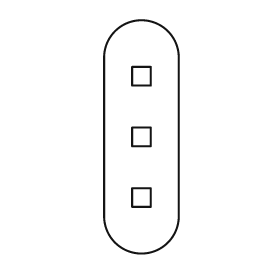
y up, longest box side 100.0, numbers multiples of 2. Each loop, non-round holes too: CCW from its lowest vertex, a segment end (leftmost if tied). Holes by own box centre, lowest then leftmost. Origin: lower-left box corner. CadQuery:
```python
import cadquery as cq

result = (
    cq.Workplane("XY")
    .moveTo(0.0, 16.0)
    .threePointArc((16.0, 0.0), (32.0, 16.0))
    .lineTo(32.0, 84.0)
    .threePointArc((16.0, 100.0), (0.0, 84.0))
    .close()
    .moveTo(12.0, 20.0)
    .lineTo(20.0, 20.0)
    .lineTo(20.0, 28.0)
    .lineTo(12.0, 28.0)
    .close()
    .moveTo(12.0, 46.0)
    .lineTo(20.0, 46.0)
    .lineTo(20.0, 54.0)
    .lineTo(12.0, 54.0)
    .close()
    .moveTo(12.0, 72.0)
    .lineTo(20.0, 72.0)
    .lineTo(20.0, 80.0)
    .lineTo(12.0, 80.0)
    .close()
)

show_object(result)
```